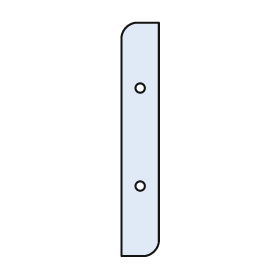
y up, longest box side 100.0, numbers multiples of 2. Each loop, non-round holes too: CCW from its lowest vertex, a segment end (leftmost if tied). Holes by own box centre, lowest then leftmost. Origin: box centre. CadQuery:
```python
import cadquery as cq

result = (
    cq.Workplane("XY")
    .moveTo(-8.0, -50.0)
    .lineTo(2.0, -50.0)
    .threePointArc((6.0, -48.0), (8.0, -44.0))
    .lineTo(8.0, 50.0)
    .lineTo(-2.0, 50.0)
    .threePointArc((-6.0, 48.0), (-8.0, 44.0))
    .close()
    .moveTo(0.0, -20.0)
    .circle(2.0)
    .moveTo(0.0, 22.0)
    .circle(2.0)
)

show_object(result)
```